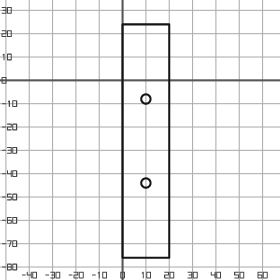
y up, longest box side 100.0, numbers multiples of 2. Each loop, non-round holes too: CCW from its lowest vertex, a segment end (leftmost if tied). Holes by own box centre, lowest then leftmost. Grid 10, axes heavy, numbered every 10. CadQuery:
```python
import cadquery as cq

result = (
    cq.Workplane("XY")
    .moveTo(0.0, -76.0)
    .lineTo(20.0, -76.0)
    .lineTo(20.0, 24.0)
    .lineTo(0.0, 24.0)
    .close()
    .moveTo(10.0, -44.0)
    .circle(2.0)
    .moveTo(10.0, -8.0)
    .circle(2.0)
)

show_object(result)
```